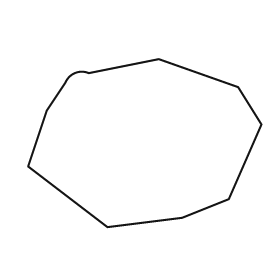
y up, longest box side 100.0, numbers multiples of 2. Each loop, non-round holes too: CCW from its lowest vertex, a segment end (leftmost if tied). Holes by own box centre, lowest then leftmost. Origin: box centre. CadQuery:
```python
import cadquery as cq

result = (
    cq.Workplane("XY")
    .moveTo(-16.0, -36.0)
    .lineTo(16.0, -32.0)
    .lineTo(36.0, -24.0)
    .lineTo(50.0, 8.0)
    .lineTo(40.0, 24.0)
    .lineTo(6.0, 36.0)
    .lineTo(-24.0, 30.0)
    .threePointArc((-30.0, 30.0), (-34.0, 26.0))
    .lineTo(-42.0, 14.0)
    .lineTo(-50.0, -10.0)
    .close()
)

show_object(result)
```